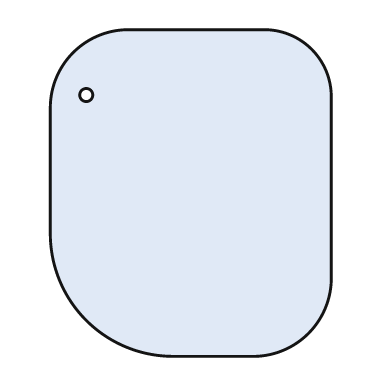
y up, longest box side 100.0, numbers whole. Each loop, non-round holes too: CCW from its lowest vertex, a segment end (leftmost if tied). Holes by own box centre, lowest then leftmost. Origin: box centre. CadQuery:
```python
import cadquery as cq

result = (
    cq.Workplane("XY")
    .moveTo(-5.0, -50.0)
    .lineTo(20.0, -50.0)
    .threePointArc((36.0, -43.0), (43.0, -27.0))
    .lineTo(43.0, 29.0)
    .threePointArc((37.0, 44.0), (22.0, 50.0))
    .lineTo(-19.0, 50.0)
    .threePointArc((-36.0, 43.0), (-43.0, 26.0))
    .lineTo(-43.0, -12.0)
    .threePointArc((-32.0, -39.0), (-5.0, -50.0))
    .close()
    .moveTo(-32.0, 30.0)
    .circle(2.0)
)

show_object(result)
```